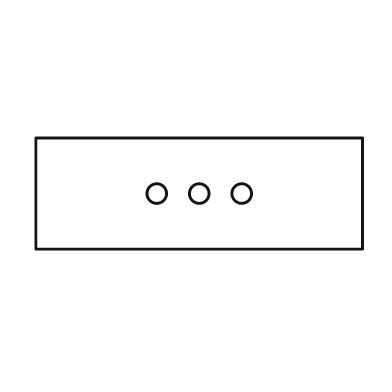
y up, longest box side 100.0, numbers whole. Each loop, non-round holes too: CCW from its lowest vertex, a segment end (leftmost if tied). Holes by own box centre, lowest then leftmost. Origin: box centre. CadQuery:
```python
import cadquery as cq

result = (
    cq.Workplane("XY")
    .moveTo(-50.0, -17.0)
    .lineTo(50.0, -17.0)
    .lineTo(50.0, 17.0)
    .lineTo(-50.0, 17.0)
    .close()
    .moveTo(-13.0, 0.0)
    .circle(3.0)
    .moveTo(0.0, 0.0)
    .circle(3.0)
    .moveTo(13.0, 0.0)
    .circle(3.0)
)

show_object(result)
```